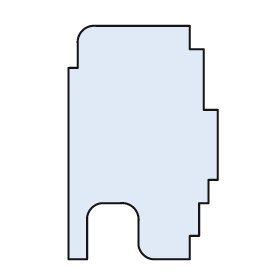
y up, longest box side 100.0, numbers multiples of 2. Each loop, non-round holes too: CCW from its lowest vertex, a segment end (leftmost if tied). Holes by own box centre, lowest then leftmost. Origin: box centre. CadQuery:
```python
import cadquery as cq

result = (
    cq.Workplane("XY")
    .moveTo(-32.0, -50.0)
    .lineTo(-24.0, -50.0)
    .lineTo(-24.0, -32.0)
    .threePointArc((-22.0, -28.0), (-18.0, -26.0))
    .lineTo(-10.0, -26.0)
    .threePointArc((-4.0, -28.0), (-2.0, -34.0))
    .lineTo(-2.0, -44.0)
    .threePointArc((0.0, -48.0), (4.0, -50.0))
    .lineTo(20.0, -50.0)
    .lineTo(20.0, -40.0)
    .lineTo(24.0, -40.0)
    .lineTo(24.0, -26.0)
    .lineTo(28.0, -26.0)
    .lineTo(28.0, -16.0)
    .lineTo(32.0, -16.0)
    .lineTo(32.0, 14.0)
    .lineTo(26.0, 14.0)
    .lineTo(26.0, 40.0)
    .lineTo(20.0, 40.0)
    .lineTo(20.0, 50.0)
    .lineTo(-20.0, 50.0)
    .threePointArc((-26.0, 48.0), (-28.0, 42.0))
    .lineTo(-28.0, 32.0)
    .lineTo(-32.0, 32.0)
    .close()
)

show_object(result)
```